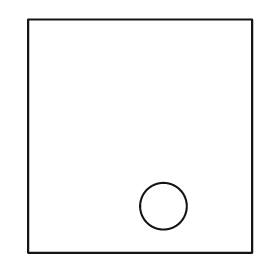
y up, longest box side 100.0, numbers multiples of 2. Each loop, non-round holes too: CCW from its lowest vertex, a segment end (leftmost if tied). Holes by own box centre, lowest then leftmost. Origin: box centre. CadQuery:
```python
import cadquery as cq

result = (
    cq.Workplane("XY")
    .moveTo(-48.0, -50.0)
    .lineTo(48.0, -50.0)
    .lineTo(48.0, 50.0)
    .lineTo(-48.0, 50.0)
    .close()
    .moveTo(10.0, -30.0)
    .circle(10.0)
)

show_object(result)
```